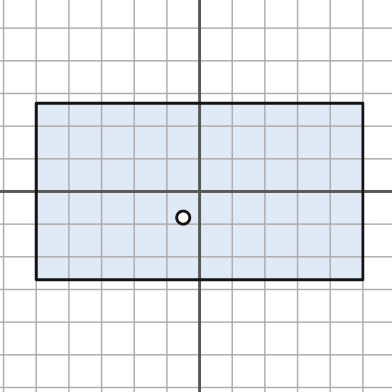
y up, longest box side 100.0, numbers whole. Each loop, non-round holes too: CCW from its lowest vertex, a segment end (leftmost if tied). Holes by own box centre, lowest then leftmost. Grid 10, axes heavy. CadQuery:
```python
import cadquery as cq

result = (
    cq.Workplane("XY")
    .moveTo(-50.0, -27.0)
    .lineTo(50.0, -27.0)
    .lineTo(50.0, 27.0)
    .lineTo(-50.0, 27.0)
    .close()
    .moveTo(-5.0, -8.0)
    .circle(2.0)
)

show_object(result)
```